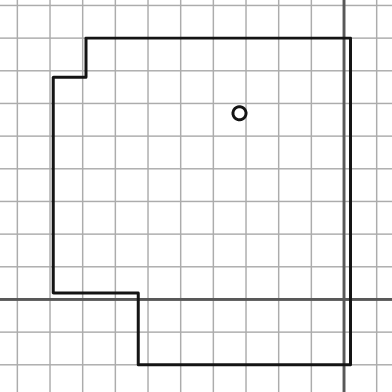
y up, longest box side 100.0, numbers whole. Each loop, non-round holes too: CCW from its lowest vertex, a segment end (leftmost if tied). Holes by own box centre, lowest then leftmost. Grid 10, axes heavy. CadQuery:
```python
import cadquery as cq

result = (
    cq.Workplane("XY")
    .moveTo(-63.0, -20.0)
    .lineTo(2.0, -20.0)
    .lineTo(2.0, 80.0)
    .lineTo(-79.0, 80.0)
    .lineTo(-79.0, 68.0)
    .lineTo(-89.0, 68.0)
    .lineTo(-89.0, 2.0)
    .lineTo(-63.0, 2.0)
    .close()
    .moveTo(-32.0, 57.0)
    .circle(2.0)
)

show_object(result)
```